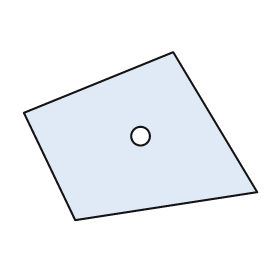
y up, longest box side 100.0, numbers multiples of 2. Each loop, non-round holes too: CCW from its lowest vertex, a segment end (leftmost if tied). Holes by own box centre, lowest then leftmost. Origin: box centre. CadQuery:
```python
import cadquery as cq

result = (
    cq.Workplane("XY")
    .moveTo(-28.0, -36.0)
    .lineTo(50.0, -24.0)
    .lineTo(14.0, 36.0)
    .lineTo(-50.0, 10.0)
    .close()
    .moveTo(0.0, 0.0)
    .circle(4.0)
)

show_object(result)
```